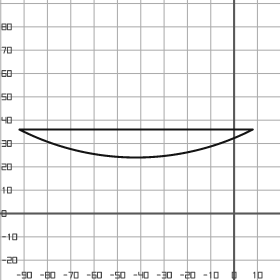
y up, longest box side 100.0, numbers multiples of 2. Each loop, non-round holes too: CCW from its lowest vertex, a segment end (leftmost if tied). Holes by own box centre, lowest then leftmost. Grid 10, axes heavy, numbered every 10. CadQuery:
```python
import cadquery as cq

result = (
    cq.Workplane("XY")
    .moveTo(-92.0, 36.0)
    .threePointArc((-42.0, 24.0), (8.0, 36.0))
    .close()
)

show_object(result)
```